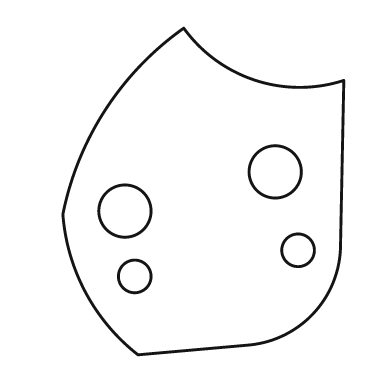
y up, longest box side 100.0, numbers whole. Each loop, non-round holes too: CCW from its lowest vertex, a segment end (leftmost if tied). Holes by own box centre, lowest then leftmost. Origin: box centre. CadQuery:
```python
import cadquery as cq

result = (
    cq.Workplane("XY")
    .moveTo(-20.0, -50.0)
    .lineTo(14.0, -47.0)
    .threePointArc((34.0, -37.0), (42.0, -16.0))
    .lineTo(43.0, 34.0)
    .threePointArc((16.0, 34.0), (-6.0, 50.0))
    .threePointArc((-30.0, 25.0), (-43.0, -7.0))
    .threePointArc((-36.0, -31.0), (-20.0, -50.0))
    .close()
    .moveTo(-21.0, -26.0)
    .circle(5.0)
    .moveTo(29.0, -18.0)
    .circle(5.0)
    .moveTo(-24.0, -6.0)
    .circle(8.0)
    .moveTo(22.0, 6.0)
    .circle(8.0)
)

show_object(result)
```